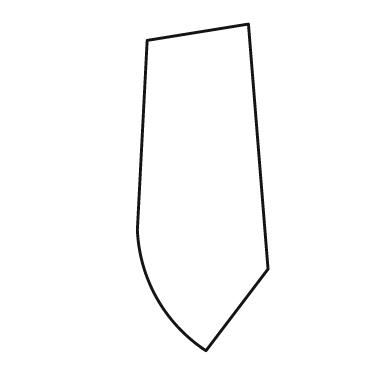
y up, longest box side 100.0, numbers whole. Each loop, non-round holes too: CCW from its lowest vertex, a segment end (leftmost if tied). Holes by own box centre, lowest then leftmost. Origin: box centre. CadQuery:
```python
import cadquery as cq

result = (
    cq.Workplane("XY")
    .moveTo(1.0, -50.0)
    .lineTo(20.0, -25.0)
    .lineTo(14.0, 50.0)
    .lineTo(-17.0, 45.0)
    .lineTo(-20.0, -13.0)
    .threePointArc((-14.0, -34.0), (1.0, -50.0))
    .close()
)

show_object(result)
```